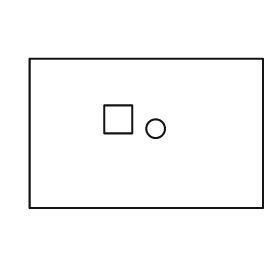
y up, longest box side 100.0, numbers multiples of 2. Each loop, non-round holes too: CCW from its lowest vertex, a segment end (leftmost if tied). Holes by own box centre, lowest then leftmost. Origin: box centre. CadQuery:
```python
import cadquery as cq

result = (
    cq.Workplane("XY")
    .moveTo(-50.0, -32.0)
    .lineTo(50.0, -32.0)
    .lineTo(50.0, 32.0)
    .lineTo(-50.0, 32.0)
    .close()
    .moveTo(4.0, 2.0)
    .circle(4.0)
    .moveTo(-18.0, 0.0)
    .lineTo(-6.0, 0.0)
    .lineTo(-6.0, 12.0)
    .lineTo(-18.0, 12.0)
    .close()
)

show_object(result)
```